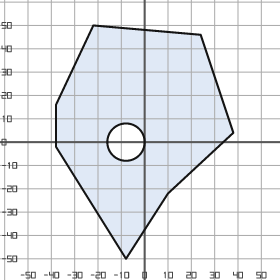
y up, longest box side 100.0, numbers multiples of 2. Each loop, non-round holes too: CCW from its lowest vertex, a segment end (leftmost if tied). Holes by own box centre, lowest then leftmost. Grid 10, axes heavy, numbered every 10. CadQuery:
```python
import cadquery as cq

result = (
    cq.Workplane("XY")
    .moveTo(-8.0, -50.0)
    .lineTo(10.0, -22.0)
    .lineTo(38.0, 4.0)
    .lineTo(24.0, 46.0)
    .lineTo(-22.0, 50.0)
    .lineTo(-38.0, 16.0)
    .lineTo(-38.0, -2.0)
    .close()
    .moveTo(-8.0, 0.0)
    .circle(8.0)
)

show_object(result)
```